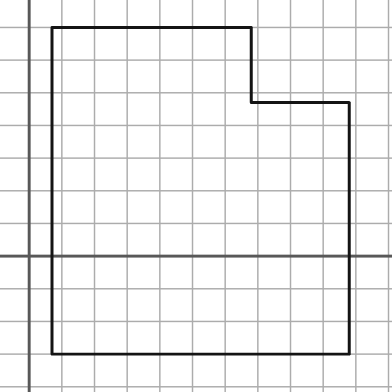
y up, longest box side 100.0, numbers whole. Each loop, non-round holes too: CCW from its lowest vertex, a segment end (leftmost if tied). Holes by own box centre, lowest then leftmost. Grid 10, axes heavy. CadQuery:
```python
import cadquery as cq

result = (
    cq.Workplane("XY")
    .moveTo(7.0, -30.0)
    .lineTo(98.0, -30.0)
    .lineTo(98.0, 47.0)
    .lineTo(68.0, 47.0)
    .lineTo(68.0, 70.0)
    .lineTo(7.0, 70.0)
    .close()
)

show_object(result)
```